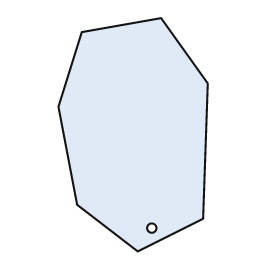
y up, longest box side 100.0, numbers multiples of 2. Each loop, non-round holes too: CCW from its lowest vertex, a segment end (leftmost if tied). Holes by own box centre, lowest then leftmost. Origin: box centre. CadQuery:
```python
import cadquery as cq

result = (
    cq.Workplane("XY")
    .moveTo(2.0, -50.0)
    .lineTo(30.0, -36.0)
    .lineTo(32.0, 22.0)
    .lineTo(12.0, 50.0)
    .lineTo(-22.0, 44.0)
    .lineTo(-32.0, 12.0)
    .lineTo(-24.0, -30.0)
    .close()
    .moveTo(8.0, -40.0)
    .circle(2.0)
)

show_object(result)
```